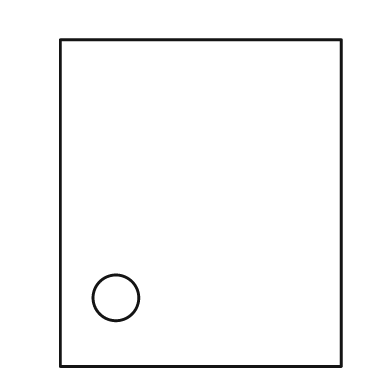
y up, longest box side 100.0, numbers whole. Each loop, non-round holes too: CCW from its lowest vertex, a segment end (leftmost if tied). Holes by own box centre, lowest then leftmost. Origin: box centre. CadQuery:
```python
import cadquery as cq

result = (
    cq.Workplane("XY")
    .moveTo(-43.0, -50.0)
    .lineTo(43.0, -50.0)
    .lineTo(43.0, 50.0)
    .lineTo(-43.0, 50.0)
    .close()
    .moveTo(-26.0, -29.0)
    .circle(7.0)
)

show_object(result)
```